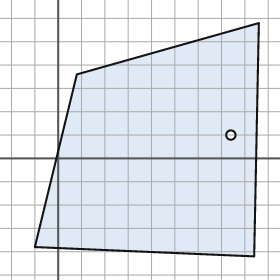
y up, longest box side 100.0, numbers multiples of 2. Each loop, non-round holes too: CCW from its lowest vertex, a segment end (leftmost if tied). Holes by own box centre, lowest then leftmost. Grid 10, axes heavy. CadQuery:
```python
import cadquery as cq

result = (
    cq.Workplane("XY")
    .moveTo(84.0, -42.0)
    .lineTo(86.0, 58.0)
    .lineTo(8.0, 36.0)
    .lineTo(-10.0, -38.0)
    .close()
    .moveTo(74.0, 10.0)
    .circle(2.0)
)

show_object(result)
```